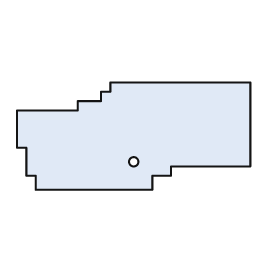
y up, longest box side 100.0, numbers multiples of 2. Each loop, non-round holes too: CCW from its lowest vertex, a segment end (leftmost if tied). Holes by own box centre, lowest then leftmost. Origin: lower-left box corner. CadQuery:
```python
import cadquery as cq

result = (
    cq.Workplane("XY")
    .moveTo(8.0, 0.0)
    .lineTo(58.0, 0.0)
    .lineTo(58.0, 6.0)
    .lineTo(66.0, 6.0)
    .lineTo(66.0, 10.0)
    .lineTo(100.0, 10.0)
    .lineTo(100.0, 46.0)
    .lineTo(40.0, 46.0)
    .lineTo(40.0, 42.0)
    .lineTo(36.0, 42.0)
    .lineTo(36.0, 38.0)
    .lineTo(26.0, 38.0)
    .lineTo(26.0, 34.0)
    .lineTo(0.0, 34.0)
    .lineTo(0.0, 18.0)
    .lineTo(4.0, 18.0)
    .lineTo(4.0, 6.0)
    .lineTo(8.0, 6.0)
    .close()
    .moveTo(50.0, 12.0)
    .circle(2.0)
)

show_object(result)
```